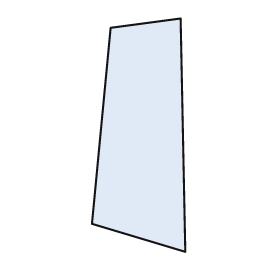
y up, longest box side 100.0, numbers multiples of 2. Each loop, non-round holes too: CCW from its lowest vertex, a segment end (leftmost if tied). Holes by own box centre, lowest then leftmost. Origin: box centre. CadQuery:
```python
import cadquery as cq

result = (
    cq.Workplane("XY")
    .moveTo(20.0, -50.0)
    .lineTo(18.0, 50.0)
    .lineTo(-12.0, 46.0)
    .lineTo(-20.0, -38.0)
    .close()
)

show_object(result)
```